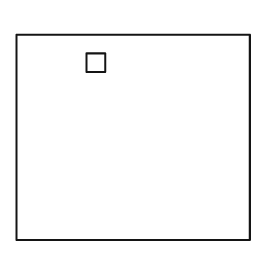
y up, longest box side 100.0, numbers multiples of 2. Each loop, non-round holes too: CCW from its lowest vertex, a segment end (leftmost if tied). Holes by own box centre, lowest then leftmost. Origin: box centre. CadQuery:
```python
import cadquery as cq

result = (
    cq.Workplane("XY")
    .moveTo(-50.0, -44.0)
    .lineTo(50.0, -44.0)
    .lineTo(50.0, 44.0)
    .lineTo(-50.0, 44.0)
    .close()
    .moveTo(-20.0, 28.0)
    .lineTo(-12.0, 28.0)
    .lineTo(-12.0, 36.0)
    .lineTo(-20.0, 36.0)
    .close()
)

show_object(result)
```